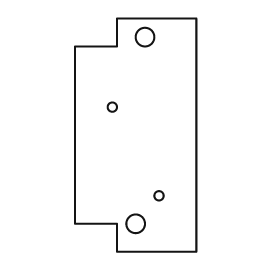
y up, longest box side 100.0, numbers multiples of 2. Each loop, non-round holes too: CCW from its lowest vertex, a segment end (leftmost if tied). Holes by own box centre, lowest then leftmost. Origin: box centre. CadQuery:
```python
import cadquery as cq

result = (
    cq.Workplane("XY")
    .moveTo(-8.0, -50.0)
    .lineTo(26.0, -50.0)
    .lineTo(26.0, 50.0)
    .lineTo(-8.0, 50.0)
    .lineTo(-8.0, 38.0)
    .lineTo(-26.0, 38.0)
    .lineTo(-26.0, -38.0)
    .lineTo(-8.0, -38.0)
    .close()
    .moveTo(0.0, -38.0)
    .circle(4.0)
    .moveTo(10.0, -26.0)
    .circle(2.0)
    .moveTo(-10.0, 12.0)
    .circle(2.0)
    .moveTo(4.0, 42.0)
    .circle(4.0)
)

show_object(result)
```